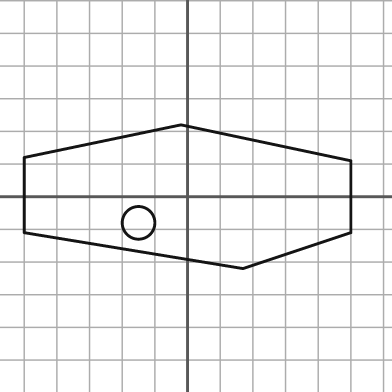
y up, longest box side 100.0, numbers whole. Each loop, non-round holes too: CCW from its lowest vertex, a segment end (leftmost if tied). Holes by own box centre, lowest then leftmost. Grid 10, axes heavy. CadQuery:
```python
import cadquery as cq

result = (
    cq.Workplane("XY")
    .moveTo(17.0, -22.0)
    .lineTo(50.0, -11.0)
    .lineTo(50.0, 11.0)
    .lineTo(-2.0, 22.0)
    .lineTo(-50.0, 12.0)
    .lineTo(-50.0, -11.0)
    .close()
    .moveTo(-15.0, -8.0)
    .circle(5.0)
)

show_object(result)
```